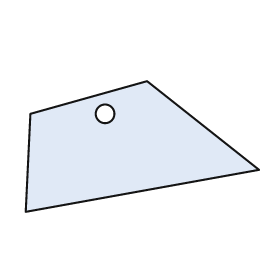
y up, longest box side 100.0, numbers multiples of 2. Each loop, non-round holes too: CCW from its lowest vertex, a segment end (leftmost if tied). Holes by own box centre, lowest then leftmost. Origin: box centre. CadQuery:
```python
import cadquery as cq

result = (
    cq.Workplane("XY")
    .moveTo(-50.0, -28.0)
    .lineTo(50.0, -10.0)
    .lineTo(2.0, 28.0)
    .lineTo(-48.0, 14.0)
    .close()
    .moveTo(-16.0, 14.0)
    .circle(4.0)
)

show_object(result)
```